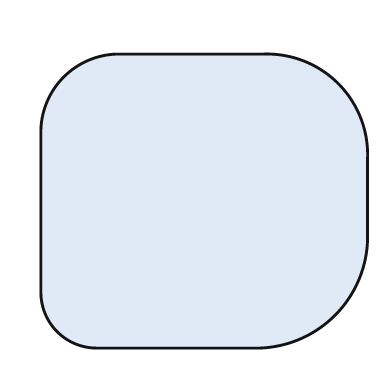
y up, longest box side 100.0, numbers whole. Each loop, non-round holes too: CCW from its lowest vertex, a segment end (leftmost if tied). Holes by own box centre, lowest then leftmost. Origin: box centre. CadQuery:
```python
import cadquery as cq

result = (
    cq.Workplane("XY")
    .moveTo(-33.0, -45.0)
    .lineTo(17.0, -45.0)
    .threePointArc((40.0, -35.0), (50.0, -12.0))
    .lineTo(50.0, 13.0)
    .threePointArc((41.0, 36.0), (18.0, 45.0))
    .lineTo(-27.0, 45.0)
    .threePointArc((-43.0, 38.0), (-50.0, 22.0))
    .lineTo(-50.0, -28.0)
    .threePointArc((-45.0, -40.0), (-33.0, -45.0))
    .close()
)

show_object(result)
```